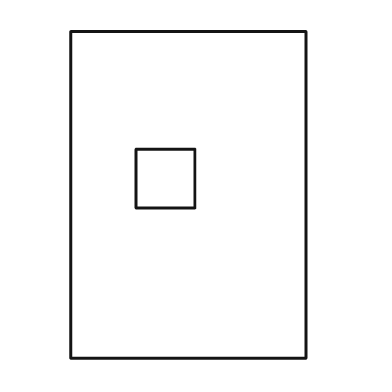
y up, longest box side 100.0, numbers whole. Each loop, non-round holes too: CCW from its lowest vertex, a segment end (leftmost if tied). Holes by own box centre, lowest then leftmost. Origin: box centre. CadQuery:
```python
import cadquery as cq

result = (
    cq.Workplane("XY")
    .moveTo(-36.0, -50.0)
    .lineTo(36.0, -50.0)
    .lineTo(36.0, 50.0)
    .lineTo(-36.0, 50.0)
    .close()
    .moveTo(-16.0, -4.0)
    .lineTo(2.0, -4.0)
    .lineTo(2.0, 14.0)
    .lineTo(-16.0, 14.0)
    .close()
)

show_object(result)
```